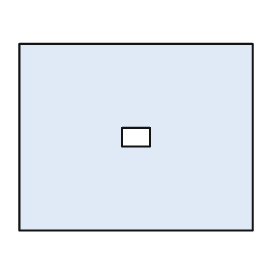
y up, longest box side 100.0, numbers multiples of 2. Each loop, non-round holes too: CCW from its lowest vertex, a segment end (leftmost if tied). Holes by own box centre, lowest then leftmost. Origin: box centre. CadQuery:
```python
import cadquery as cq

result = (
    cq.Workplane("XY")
    .moveTo(-50.0, -40.0)
    .lineTo(50.0, -40.0)
    .lineTo(50.0, 40.0)
    .lineTo(-50.0, 40.0)
    .close()
    .moveTo(-6.0, -4.0)
    .lineTo(6.0, -4.0)
    .lineTo(6.0, 4.0)
    .lineTo(-6.0, 4.0)
    .close()
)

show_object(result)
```